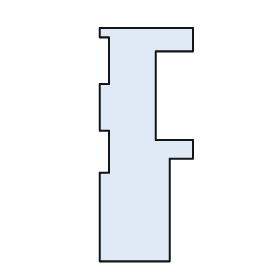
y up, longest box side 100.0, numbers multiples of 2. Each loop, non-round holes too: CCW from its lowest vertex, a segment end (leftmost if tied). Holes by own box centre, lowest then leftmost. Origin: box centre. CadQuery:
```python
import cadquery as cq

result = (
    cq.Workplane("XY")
    .moveTo(-20.0, -50.0)
    .lineTo(10.0, -50.0)
    .lineTo(10.0, -6.0)
    .lineTo(20.0, -6.0)
    .lineTo(20.0, 2.0)
    .lineTo(4.0, 2.0)
    .lineTo(4.0, 40.0)
    .lineTo(20.0, 40.0)
    .lineTo(20.0, 50.0)
    .lineTo(-20.0, 50.0)
    .lineTo(-20.0, 46.0)
    .lineTo(-16.0, 46.0)
    .lineTo(-16.0, 26.0)
    .lineTo(-20.0, 26.0)
    .lineTo(-20.0, 6.0)
    .lineTo(-16.0, 6.0)
    .lineTo(-16.0, -12.0)
    .lineTo(-20.0, -12.0)
    .close()
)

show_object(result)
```